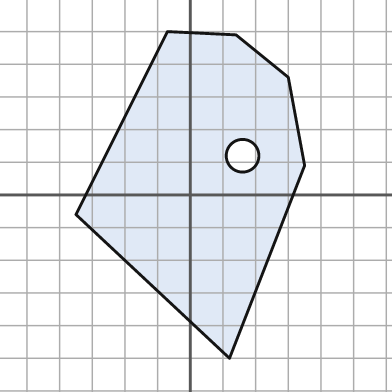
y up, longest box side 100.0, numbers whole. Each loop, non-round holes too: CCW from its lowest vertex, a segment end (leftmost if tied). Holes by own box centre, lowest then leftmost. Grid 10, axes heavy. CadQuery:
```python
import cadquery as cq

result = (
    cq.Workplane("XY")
    .moveTo(12.0, -50.0)
    .lineTo(35.0, 9.0)
    .lineTo(30.0, 36.0)
    .lineTo(14.0, 49.0)
    .lineTo(-7.0, 50.0)
    .lineTo(-35.0, -6.0)
    .close()
    .moveTo(16.0, 12.0)
    .circle(5.0)
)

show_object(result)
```